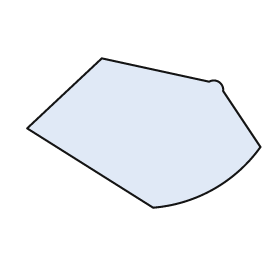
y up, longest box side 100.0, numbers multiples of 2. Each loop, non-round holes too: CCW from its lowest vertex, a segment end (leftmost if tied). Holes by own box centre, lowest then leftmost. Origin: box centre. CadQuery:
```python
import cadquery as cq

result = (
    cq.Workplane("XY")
    .moveTo(4.0, -32.0)
    .threePointArc((30.0, -24.0), (50.0, -6.0))
    .lineTo(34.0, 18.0)
    .threePointArc((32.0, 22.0), (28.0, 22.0))
    .lineTo(-18.0, 32.0)
    .lineTo(-50.0, 2.0)
    .close()
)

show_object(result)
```